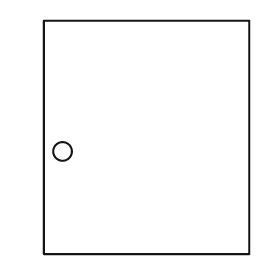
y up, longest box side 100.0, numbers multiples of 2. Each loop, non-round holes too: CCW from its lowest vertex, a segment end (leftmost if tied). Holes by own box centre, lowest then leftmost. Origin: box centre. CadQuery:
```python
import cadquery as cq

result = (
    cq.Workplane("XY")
    .moveTo(-44.0, -50.0)
    .lineTo(44.0, -50.0)
    .lineTo(44.0, 50.0)
    .lineTo(-44.0, 50.0)
    .close()
    .moveTo(-36.0, -6.0)
    .circle(4.0)
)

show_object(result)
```